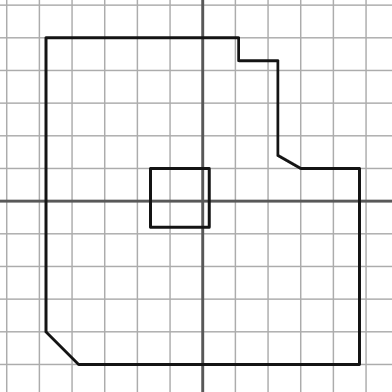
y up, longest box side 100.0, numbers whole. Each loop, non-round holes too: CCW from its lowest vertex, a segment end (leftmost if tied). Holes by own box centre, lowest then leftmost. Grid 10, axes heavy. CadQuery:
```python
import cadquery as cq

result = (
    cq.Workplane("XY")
    .moveTo(-38.0, -50.0)
    .lineTo(48.0, -50.0)
    .lineTo(48.0, 10.0)
    .lineTo(30.0, 10.0)
    .lineTo(23.0, 14.0)
    .lineTo(23.0, 43.0)
    .lineTo(11.0, 43.0)
    .lineTo(11.0, 50.0)
    .lineTo(-48.0, 50.0)
    .lineTo(-48.0, -40.0)
    .close()
    .moveTo(-16.0, -8.0)
    .lineTo(2.0, -8.0)
    .lineTo(2.0, 10.0)
    .lineTo(-16.0, 10.0)
    .close()
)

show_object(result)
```